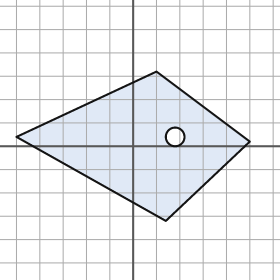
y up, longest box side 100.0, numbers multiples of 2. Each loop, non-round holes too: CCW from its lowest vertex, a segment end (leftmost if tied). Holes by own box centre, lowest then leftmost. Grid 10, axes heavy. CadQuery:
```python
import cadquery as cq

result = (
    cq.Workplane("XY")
    .moveTo(14.0, -32.0)
    .lineTo(50.0, 2.0)
    .lineTo(10.0, 32.0)
    .lineTo(-50.0, 4.0)
    .close()
    .moveTo(18.0, 4.0)
    .circle(4.0)
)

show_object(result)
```